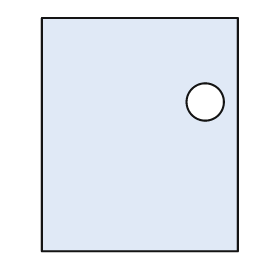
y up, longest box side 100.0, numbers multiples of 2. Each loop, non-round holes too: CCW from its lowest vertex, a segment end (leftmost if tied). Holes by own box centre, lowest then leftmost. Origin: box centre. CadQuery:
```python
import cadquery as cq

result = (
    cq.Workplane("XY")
    .moveTo(-42.0, -50.0)
    .lineTo(42.0, -50.0)
    .lineTo(42.0, 50.0)
    .lineTo(-42.0, 50.0)
    .close()
    .moveTo(28.0, 14.0)
    .circle(8.0)
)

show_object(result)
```